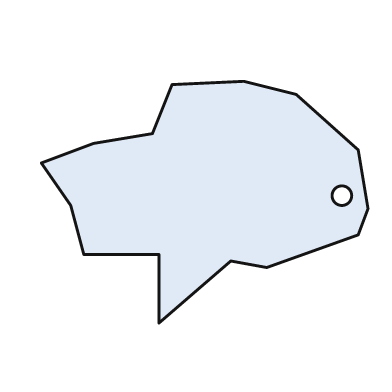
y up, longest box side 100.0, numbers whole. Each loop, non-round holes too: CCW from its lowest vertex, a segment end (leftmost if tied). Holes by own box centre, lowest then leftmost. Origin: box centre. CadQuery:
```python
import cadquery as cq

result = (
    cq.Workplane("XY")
    .moveTo(-14.0, -37.0)
    .lineTo(8.0, -18.0)
    .lineTo(19.0, -20.0)
    .lineTo(47.0, -10.0)
    .lineTo(50.0, -2.0)
    .lineTo(47.0, 16.0)
    .lineTo(28.0, 33.0)
    .lineTo(12.0, 37.0)
    .lineTo(-10.0, 36.0)
    .lineTo(-16.0, 21.0)
    .lineTo(-34.0, 18.0)
    .lineTo(-50.0, 12.0)
    .lineTo(-41.0, -1.0)
    .lineTo(-37.0, -16.0)
    .lineTo(-14.0, -16.0)
    .close()
    .moveTo(42.0, 2.0)
    .circle(3.0)
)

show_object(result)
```